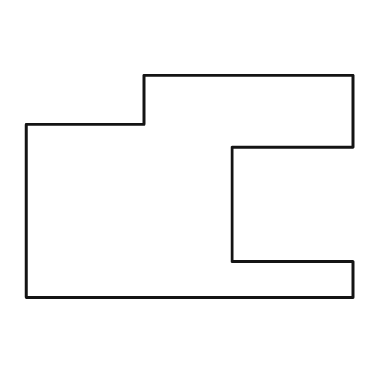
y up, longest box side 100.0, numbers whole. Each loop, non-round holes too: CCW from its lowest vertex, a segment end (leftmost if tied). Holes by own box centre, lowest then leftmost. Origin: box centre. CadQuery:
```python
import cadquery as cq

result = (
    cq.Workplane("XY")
    .moveTo(-50.0, -34.0)
    .lineTo(50.0, -34.0)
    .lineTo(50.0, -23.0)
    .lineTo(13.0, -23.0)
    .lineTo(13.0, 12.0)
    .lineTo(50.0, 12.0)
    .lineTo(50.0, 34.0)
    .lineTo(-14.0, 34.0)
    .lineTo(-14.0, 19.0)
    .lineTo(-50.0, 19.0)
    .close()
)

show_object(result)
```